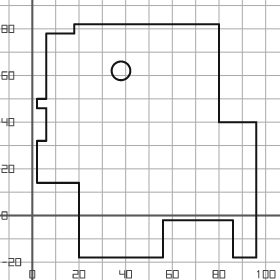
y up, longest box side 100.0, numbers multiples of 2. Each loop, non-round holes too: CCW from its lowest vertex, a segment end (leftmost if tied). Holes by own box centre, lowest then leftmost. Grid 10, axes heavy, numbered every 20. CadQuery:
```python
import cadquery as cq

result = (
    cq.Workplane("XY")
    .moveTo(20.0, -18.0)
    .lineTo(56.0, -18.0)
    .lineTo(56.0, -2.0)
    .lineTo(86.0, -2.0)
    .lineTo(86.0, -18.0)
    .lineTo(96.0, -18.0)
    .lineTo(96.0, 40.0)
    .lineTo(80.0, 40.0)
    .lineTo(80.0, 82.0)
    .lineTo(18.0, 82.0)
    .lineTo(18.0, 78.0)
    .lineTo(6.0, 78.0)
    .lineTo(6.0, 50.0)
    .lineTo(2.0, 50.0)
    .lineTo(2.0, 46.0)
    .lineTo(6.0, 46.0)
    .lineTo(6.0, 32.0)
    .lineTo(2.0, 32.0)
    .lineTo(2.0, 14.0)
    .lineTo(20.0, 14.0)
    .close()
    .moveTo(38.0, 62.0)
    .circle(4.0)
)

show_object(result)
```